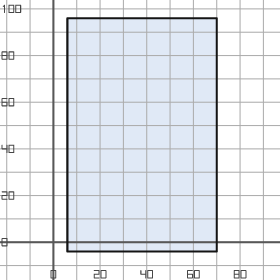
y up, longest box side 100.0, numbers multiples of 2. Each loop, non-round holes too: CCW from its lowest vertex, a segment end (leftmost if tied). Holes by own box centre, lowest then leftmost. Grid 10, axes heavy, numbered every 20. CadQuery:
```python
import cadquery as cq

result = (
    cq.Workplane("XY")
    .moveTo(6.0, -4.0)
    .lineTo(70.0, -4.0)
    .lineTo(70.0, 96.0)
    .lineTo(6.0, 96.0)
    .close()
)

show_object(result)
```